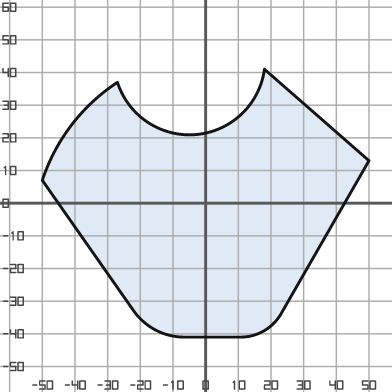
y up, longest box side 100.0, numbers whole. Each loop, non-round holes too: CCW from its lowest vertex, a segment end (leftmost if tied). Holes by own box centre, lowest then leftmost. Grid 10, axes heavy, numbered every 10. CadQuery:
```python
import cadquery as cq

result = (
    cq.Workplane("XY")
    .moveTo(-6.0, -41.0)
    .lineTo(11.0, -41.0)
    .threePointArc((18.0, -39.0), (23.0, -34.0))
    .lineTo(50.0, 13.0)
    .lineTo(18.0, 41.0)
    .threePointArc((-3.0, 21.0), (-27.0, 37.0))
    .threePointArc((-41.0, 24.0), (-50.0, 7.0))
    .lineTo(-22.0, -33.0)
    .threePointArc((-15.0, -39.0), (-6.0, -41.0))
    .close()
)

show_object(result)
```